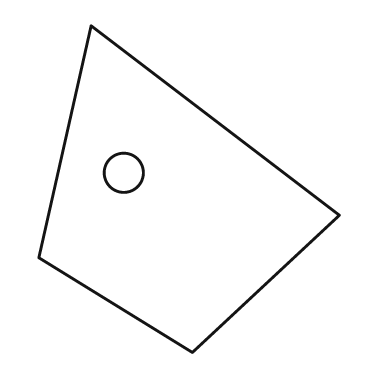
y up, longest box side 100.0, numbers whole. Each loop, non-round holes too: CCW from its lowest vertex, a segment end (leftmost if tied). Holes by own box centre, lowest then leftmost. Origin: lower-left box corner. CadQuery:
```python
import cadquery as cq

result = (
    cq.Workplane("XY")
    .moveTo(47.0, 0.0)
    .lineTo(92.0, 42.0)
    .lineTo(16.0, 100.0)
    .lineTo(0.0, 29.0)
    .close()
    .moveTo(26.0, 55.0)
    .circle(6.0)
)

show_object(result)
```